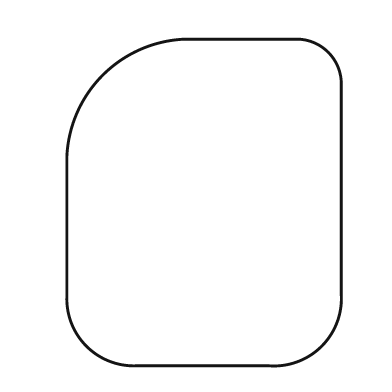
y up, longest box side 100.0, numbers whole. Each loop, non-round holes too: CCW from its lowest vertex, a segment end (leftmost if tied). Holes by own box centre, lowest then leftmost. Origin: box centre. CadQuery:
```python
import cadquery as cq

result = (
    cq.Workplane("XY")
    .moveTo(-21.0, -50.0)
    .lineTo(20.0, -50.0)
    .threePointArc((36.0, -44.0), (42.0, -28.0))
    .lineTo(42.0, 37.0)
    .threePointArc((38.0, 46.0), (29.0, 50.0))
    .lineTo(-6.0, 50.0)
    .threePointArc((-31.0, 39.0), (-42.0, 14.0))
    .lineTo(-42.0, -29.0)
    .threePointArc((-36.0, -44.0), (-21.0, -50.0))
    .close()
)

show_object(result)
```